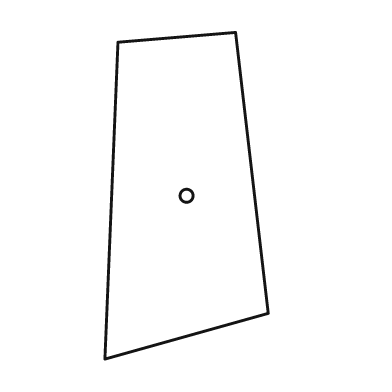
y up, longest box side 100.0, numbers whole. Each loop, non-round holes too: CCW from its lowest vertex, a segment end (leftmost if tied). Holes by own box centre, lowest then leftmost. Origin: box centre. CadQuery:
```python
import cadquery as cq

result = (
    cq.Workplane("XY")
    .moveTo(-25.0, -50.0)
    .lineTo(25.0, -36.0)
    .lineTo(15.0, 50.0)
    .lineTo(-21.0, 47.0)
    .close()
    .moveTo(0.0, 0.0)
    .circle(2.0)
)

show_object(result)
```